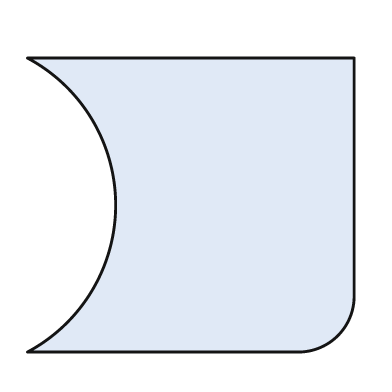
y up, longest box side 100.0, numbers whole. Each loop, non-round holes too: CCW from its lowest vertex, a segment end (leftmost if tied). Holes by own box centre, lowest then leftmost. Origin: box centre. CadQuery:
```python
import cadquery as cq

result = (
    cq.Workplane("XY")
    .moveTo(-50.0, -45.0)
    .lineTo(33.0, -45.0)
    .threePointArc((45.0, -40.0), (50.0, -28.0))
    .lineTo(50.0, 45.0)
    .lineTo(-50.0, 45.0)
    .threePointArc((-23.0, 0.0), (-50.0, -45.0))
    .close()
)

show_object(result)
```